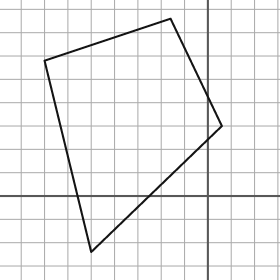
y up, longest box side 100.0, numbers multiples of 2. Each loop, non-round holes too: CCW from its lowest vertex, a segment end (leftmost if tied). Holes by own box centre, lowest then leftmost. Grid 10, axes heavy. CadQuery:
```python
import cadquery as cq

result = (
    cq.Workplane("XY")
    .moveTo(-50.0, -24.0)
    .lineTo(6.0, 30.0)
    .lineTo(-16.0, 76.0)
    .lineTo(-70.0, 58.0)
    .close()
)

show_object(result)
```